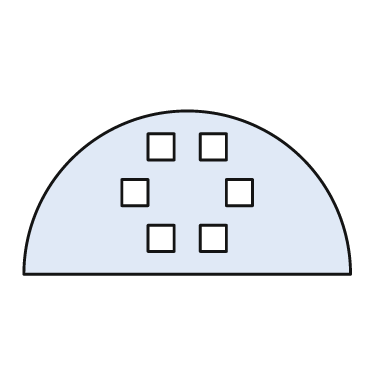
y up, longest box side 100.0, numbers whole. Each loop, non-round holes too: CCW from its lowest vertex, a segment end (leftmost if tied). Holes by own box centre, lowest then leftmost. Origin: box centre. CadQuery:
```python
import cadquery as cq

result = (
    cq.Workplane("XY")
    .moveTo(-50.0, -25.0)
    .lineTo(50.0, -25.0)
    .threePointArc((0.0, 25.0), (-50.0, -25.0))
    .close()
    .moveTo(-12.0, -18.0)
    .lineTo(-4.0, -18.0)
    .lineTo(-4.0, -10.0)
    .lineTo(-12.0, -10.0)
    .close()
    .moveTo(4.0, -18.0)
    .lineTo(12.0, -18.0)
    .lineTo(12.0, -10.0)
    .lineTo(4.0, -10.0)
    .close()
    .moveTo(-20.0, -4.0)
    .lineTo(-12.0, -4.0)
    .lineTo(-12.0, 4.0)
    .lineTo(-20.0, 4.0)
    .close()
    .moveTo(12.0, -4.0)
    .lineTo(20.0, -4.0)
    .lineTo(20.0, 4.0)
    .lineTo(12.0, 4.0)
    .close()
    .moveTo(-12.0, 10.0)
    .lineTo(-4.0, 10.0)
    .lineTo(-4.0, 18.0)
    .lineTo(-12.0, 18.0)
    .close()
    .moveTo(4.0, 10.0)
    .lineTo(12.0, 10.0)
    .lineTo(12.0, 18.0)
    .lineTo(4.0, 18.0)
    .close()
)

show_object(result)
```